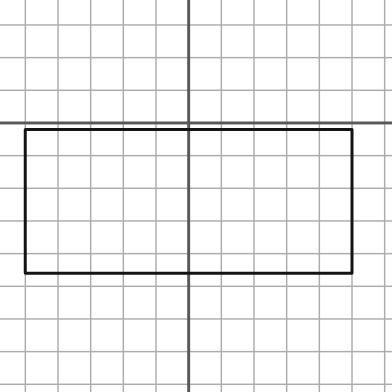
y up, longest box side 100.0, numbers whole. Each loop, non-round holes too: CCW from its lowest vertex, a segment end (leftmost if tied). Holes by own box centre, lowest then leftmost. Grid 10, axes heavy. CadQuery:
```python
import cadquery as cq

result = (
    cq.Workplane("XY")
    .moveTo(-50.0, -46.0)
    .lineTo(50.0, -46.0)
    .lineTo(50.0, -2.0)
    .lineTo(-50.0, -2.0)
    .close()
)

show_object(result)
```